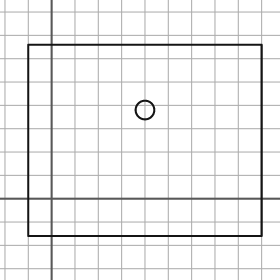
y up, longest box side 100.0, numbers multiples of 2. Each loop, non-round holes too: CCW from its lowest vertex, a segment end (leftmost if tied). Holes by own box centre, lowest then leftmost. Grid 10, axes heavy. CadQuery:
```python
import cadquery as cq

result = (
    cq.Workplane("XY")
    .moveTo(-10.0, -16.0)
    .lineTo(90.0, -16.0)
    .lineTo(90.0, 66.0)
    .lineTo(-10.0, 66.0)
    .close()
    .moveTo(40.0, 38.0)
    .circle(4.0)
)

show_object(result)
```